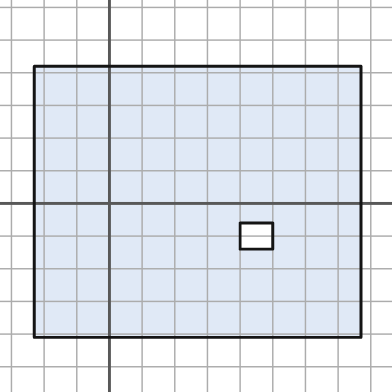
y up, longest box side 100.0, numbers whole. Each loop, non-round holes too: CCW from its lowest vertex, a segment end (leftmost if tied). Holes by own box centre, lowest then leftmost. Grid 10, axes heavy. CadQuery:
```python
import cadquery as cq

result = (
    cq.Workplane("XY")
    .moveTo(-23.0, -41.0)
    .lineTo(77.0, -41.0)
    .lineTo(77.0, 42.0)
    .lineTo(-23.0, 42.0)
    .close()
    .moveTo(40.0, -14.0)
    .lineTo(50.0, -14.0)
    .lineTo(50.0, -6.0)
    .lineTo(40.0, -6.0)
    .close()
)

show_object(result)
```